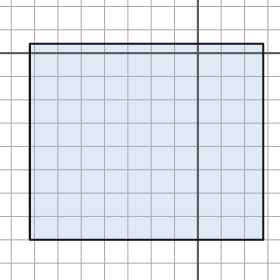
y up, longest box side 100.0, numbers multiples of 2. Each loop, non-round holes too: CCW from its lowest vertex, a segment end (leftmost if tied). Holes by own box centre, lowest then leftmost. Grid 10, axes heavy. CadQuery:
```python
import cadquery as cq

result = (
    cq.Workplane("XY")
    .moveTo(-72.0, -80.0)
    .lineTo(28.0, -80.0)
    .lineTo(28.0, 4.0)
    .lineTo(-72.0, 4.0)
    .close()
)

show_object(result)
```